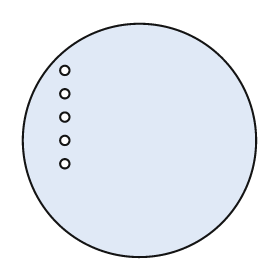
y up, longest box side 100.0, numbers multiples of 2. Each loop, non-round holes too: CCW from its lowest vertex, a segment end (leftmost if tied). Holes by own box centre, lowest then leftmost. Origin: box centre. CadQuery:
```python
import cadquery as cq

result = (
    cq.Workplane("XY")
    .moveTo(0.0, 0.0)
    .circle(50.0)
    .moveTo(-32.0, -10.0)
    .circle(2.0)
    .moveTo(-32.0, 0.0)
    .circle(2.0)
    .moveTo(-32.0, 10.0)
    .circle(2.0)
    .moveTo(-32.0, 20.0)
    .circle(2.0)
    .moveTo(-32.0, 30.0)
    .circle(2.0)
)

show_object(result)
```